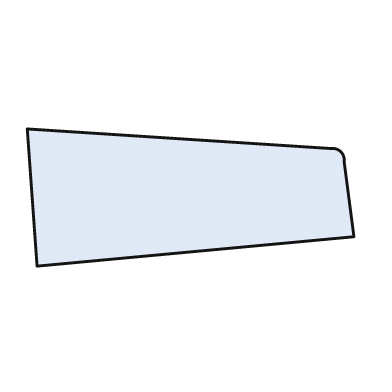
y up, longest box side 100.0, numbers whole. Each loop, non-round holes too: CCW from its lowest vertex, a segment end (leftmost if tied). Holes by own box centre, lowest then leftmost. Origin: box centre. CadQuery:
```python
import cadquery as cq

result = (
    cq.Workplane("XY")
    .moveTo(-47.0, -21.0)
    .lineTo(50.0, -12.0)
    .lineTo(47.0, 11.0)
    .threePointArc((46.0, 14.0), (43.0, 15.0))
    .lineTo(-50.0, 21.0)
    .close()
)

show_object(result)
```